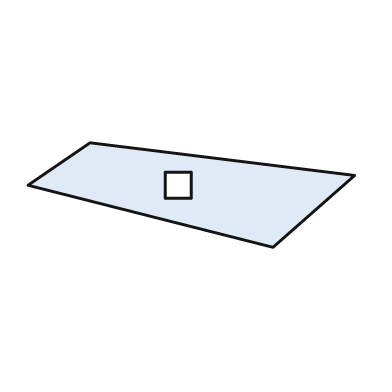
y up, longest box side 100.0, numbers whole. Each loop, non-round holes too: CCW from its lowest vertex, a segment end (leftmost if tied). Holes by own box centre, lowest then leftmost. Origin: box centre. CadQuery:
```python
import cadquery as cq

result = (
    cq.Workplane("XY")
    .moveTo(25.0, -16.0)
    .lineTo(50.0, 6.0)
    .lineTo(-31.0, 16.0)
    .lineTo(-50.0, 3.0)
    .close()
    .moveTo(-8.0, -1.0)
    .lineTo(0.0, -1.0)
    .lineTo(0.0, 7.0)
    .lineTo(-8.0, 7.0)
    .close()
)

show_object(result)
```